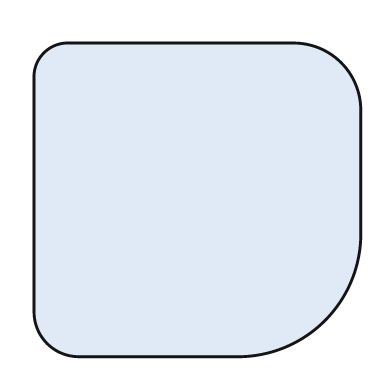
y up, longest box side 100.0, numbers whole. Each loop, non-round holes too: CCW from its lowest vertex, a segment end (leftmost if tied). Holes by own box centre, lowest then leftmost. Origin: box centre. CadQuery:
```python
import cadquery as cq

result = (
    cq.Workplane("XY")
    .moveTo(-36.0, -48.0)
    .lineTo(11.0, -48.0)
    .threePointArc((39.0, -37.0), (50.0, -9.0))
    .lineTo(50.0, 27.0)
    .threePointArc((44.0, 42.0), (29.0, 48.0))
    .lineTo(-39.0, 48.0)
    .threePointArc((-47.0, 45.0), (-50.0, 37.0))
    .lineTo(-50.0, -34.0)
    .threePointArc((-46.0, -44.0), (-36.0, -48.0))
    .close()
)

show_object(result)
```